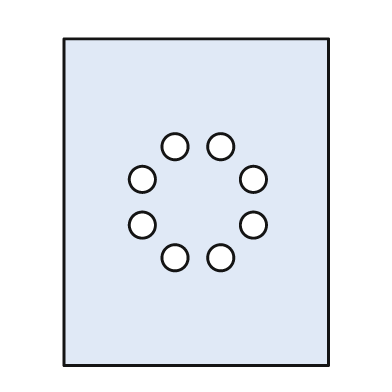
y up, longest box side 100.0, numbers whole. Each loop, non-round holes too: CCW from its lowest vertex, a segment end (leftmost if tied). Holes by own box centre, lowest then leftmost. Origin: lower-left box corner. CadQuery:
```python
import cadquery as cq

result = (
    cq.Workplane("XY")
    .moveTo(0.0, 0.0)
    .lineTo(81.0, 0.0)
    .lineTo(81.0, 100.0)
    .lineTo(0.0, 100.0)
    .close()
    .moveTo(34.0, 33.0)
    .circle(4.0)
    .moveTo(48.0, 33.0)
    .circle(4.0)
    .moveTo(24.0, 43.0)
    .circle(4.0)
    .moveTo(58.0, 43.0)
    .circle(4.0)
    .moveTo(24.0, 57.0)
    .circle(4.0)
    .moveTo(58.0, 57.0)
    .circle(4.0)
    .moveTo(34.0, 67.0)
    .circle(4.0)
    .moveTo(48.0, 67.0)
    .circle(4.0)
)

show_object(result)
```